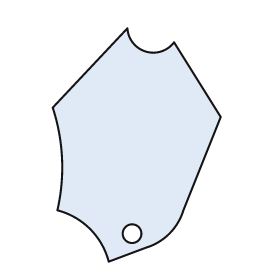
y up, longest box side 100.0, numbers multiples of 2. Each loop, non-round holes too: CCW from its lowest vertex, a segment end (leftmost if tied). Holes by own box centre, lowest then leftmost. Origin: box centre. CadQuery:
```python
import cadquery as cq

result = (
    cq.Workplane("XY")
    .moveTo(-12.0, -50.0)
    .lineTo(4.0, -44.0)
    .threePointArc((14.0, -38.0), (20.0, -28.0))
    .lineTo(36.0, 12.0)
    .lineTo(16.0, 44.0)
    .threePointArc((4.0, 40.0), (-4.0, 50.0))
    .lineTo(-36.0, 16.0)
    .threePointArc((-32.0, -6.0), (-34.0, -28.0))
    .threePointArc((-20.0, -36.0), (-12.0, -50.0))
    .close()
    .moveTo(-2.0, -38.0)
    .circle(4.0)
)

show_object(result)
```